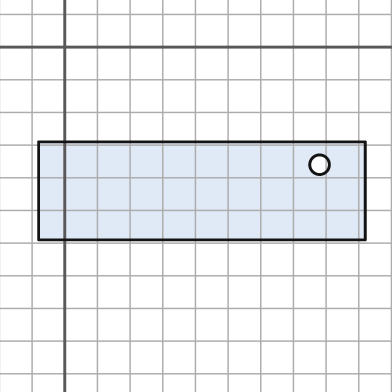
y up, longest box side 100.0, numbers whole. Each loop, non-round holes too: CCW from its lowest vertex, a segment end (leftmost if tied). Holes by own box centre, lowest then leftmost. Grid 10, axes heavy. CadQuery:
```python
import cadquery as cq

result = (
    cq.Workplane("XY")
    .moveTo(-8.0, -59.0)
    .lineTo(92.0, -59.0)
    .lineTo(92.0, -29.0)
    .lineTo(-8.0, -29.0)
    .close()
    .moveTo(78.0, -36.0)
    .circle(3.0)
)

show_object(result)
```